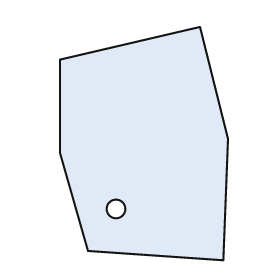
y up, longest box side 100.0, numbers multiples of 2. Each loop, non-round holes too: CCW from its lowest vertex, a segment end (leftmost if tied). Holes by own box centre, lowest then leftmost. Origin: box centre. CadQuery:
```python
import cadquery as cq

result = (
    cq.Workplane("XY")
    .moveTo(34.0, -50.0)
    .lineTo(36.0, 2.0)
    .lineTo(24.0, 50.0)
    .lineTo(-36.0, 36.0)
    .lineTo(-36.0, -4.0)
    .lineTo(-24.0, -46.0)
    .close()
    .moveTo(-12.0, -28.0)
    .circle(4.0)
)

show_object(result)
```